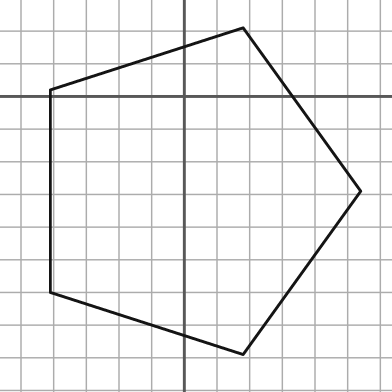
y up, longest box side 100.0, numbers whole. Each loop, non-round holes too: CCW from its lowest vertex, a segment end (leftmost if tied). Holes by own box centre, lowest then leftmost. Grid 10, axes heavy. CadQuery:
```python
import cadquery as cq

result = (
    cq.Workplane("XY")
    .moveTo(18.0, -79.0)
    .lineTo(54.0, -29.0)
    .lineTo(18.0, 21.0)
    .lineTo(-41.0, 2.0)
    .lineTo(-41.0, -60.0)
    .close()
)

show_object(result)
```